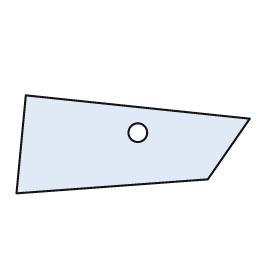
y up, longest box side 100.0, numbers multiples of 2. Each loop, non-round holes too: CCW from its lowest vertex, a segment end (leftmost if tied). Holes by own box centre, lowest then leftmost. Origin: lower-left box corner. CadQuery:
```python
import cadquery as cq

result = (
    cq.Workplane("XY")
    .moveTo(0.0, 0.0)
    .lineTo(82.0, 6.0)
    .lineTo(100.0, 32.0)
    .lineTo(4.0, 42.0)
    .close()
    .moveTo(52.0, 26.0)
    .circle(4.0)
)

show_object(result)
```